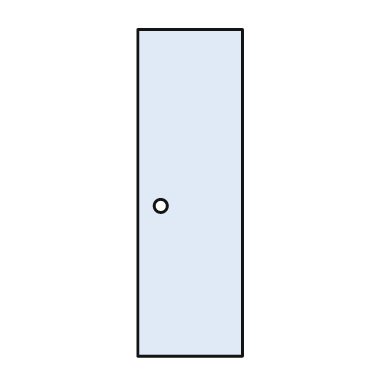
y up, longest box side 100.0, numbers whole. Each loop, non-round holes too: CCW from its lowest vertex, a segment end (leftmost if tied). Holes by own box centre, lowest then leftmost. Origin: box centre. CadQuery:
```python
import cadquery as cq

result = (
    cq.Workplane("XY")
    .moveTo(-16.0, -50.0)
    .lineTo(16.0, -50.0)
    .lineTo(16.0, 50.0)
    .lineTo(-16.0, 50.0)
    .close()
    .moveTo(-9.0, -4.0)
    .circle(2.0)
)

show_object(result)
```